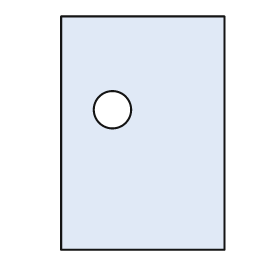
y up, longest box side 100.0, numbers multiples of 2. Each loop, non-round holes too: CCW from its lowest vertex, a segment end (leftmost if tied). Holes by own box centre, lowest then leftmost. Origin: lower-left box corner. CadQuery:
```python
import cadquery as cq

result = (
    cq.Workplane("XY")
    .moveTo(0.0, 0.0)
    .lineTo(70.0, 0.0)
    .lineTo(70.0, 100.0)
    .lineTo(0.0, 100.0)
    .close()
    .moveTo(22.0, 60.0)
    .circle(8.0)
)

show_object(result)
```